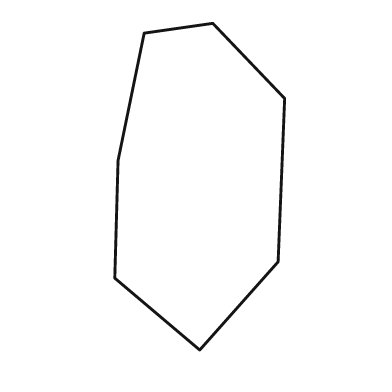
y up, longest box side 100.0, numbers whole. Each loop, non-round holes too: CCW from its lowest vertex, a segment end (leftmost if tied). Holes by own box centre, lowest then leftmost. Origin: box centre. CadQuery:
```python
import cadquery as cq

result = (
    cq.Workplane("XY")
    .moveTo(0.0, -50.0)
    .lineTo(24.0, -23.0)
    .lineTo(26.0, 27.0)
    .lineTo(4.0, 50.0)
    .lineTo(-17.0, 47.0)
    .lineTo(-25.0, 8.0)
    .lineTo(-26.0, -28.0)
    .close()
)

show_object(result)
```